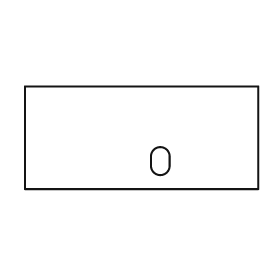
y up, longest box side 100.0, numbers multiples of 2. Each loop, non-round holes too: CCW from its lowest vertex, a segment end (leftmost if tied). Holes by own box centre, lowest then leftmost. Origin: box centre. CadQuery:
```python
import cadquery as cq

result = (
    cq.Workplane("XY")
    .moveTo(-50.0, -22.0)
    .lineTo(50.0, -22.0)
    .lineTo(50.0, 22.0)
    .lineTo(-50.0, 22.0)
    .close()
    .moveTo(4.0, -12.0)
    .threePointArc((8.0, -16.0), (12.0, -12.0))
    .lineTo(12.0, -8.0)
    .threePointArc((8.0, -4.0), (4.0, -8.0))
    .close()
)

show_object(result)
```